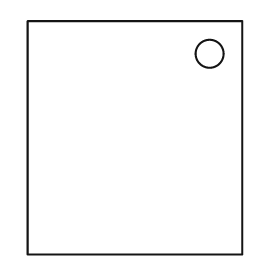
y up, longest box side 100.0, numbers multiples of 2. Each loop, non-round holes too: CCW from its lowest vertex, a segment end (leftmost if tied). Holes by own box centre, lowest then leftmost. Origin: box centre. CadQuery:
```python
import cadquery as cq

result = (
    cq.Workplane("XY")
    .moveTo(-46.0, -50.0)
    .lineTo(46.0, -50.0)
    .lineTo(46.0, 50.0)
    .lineTo(-46.0, 50.0)
    .close()
    .moveTo(32.0, 36.0)
    .circle(6.0)
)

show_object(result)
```